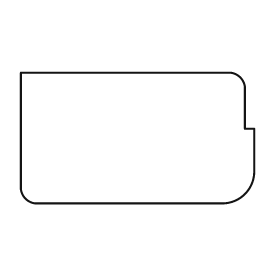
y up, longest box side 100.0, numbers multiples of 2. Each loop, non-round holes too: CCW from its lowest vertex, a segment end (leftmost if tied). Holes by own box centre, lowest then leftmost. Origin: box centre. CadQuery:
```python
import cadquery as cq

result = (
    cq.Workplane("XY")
    .moveTo(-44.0, -28.0)
    .lineTo(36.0, -28.0)
    .threePointArc((46.0, -24.0), (50.0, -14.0))
    .lineTo(50.0, 4.0)
    .lineTo(46.0, 4.0)
    .lineTo(46.0, 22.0)
    .threePointArc((44.0, 26.0), (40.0, 28.0))
    .lineTo(-50.0, 28.0)
    .lineTo(-50.0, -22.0)
    .threePointArc((-48.0, -26.0), (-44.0, -28.0))
    .close()
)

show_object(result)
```